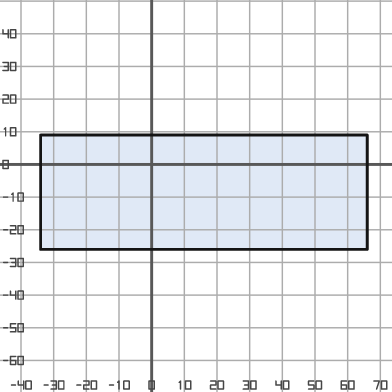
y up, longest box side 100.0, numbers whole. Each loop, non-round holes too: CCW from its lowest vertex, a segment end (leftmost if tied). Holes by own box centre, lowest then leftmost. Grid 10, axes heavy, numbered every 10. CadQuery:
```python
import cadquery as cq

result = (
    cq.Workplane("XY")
    .moveTo(-34.0, -26.0)
    .lineTo(66.0, -26.0)
    .lineTo(66.0, 9.0)
    .lineTo(-34.0, 9.0)
    .close()
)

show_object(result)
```